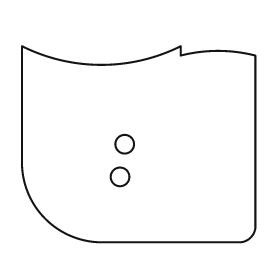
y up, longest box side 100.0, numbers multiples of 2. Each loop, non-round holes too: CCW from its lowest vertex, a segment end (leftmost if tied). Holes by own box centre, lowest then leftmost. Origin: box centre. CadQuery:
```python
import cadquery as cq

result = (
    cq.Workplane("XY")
    .moveTo(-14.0, -42.0)
    .lineTo(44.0, -42.0)
    .threePointArc((48.0, -40.0), (50.0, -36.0))
    .lineTo(50.0, 38.0)
    .threePointArc((34.0, 40.0), (18.0, 38.0))
    .lineTo(18.0, 42.0)
    .threePointArc((-16.0, 34.0), (-50.0, 42.0))
    .lineTo(-50.0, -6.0)
    .threePointArc((-40.0, -32.0), (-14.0, -42.0))
    .close()
    .moveTo(-8.0, -14.0)
    .circle(4.0)
    .moveTo(-6.0, 0.0)
    .circle(4.0)
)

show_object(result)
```